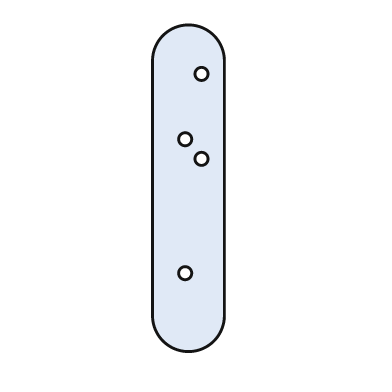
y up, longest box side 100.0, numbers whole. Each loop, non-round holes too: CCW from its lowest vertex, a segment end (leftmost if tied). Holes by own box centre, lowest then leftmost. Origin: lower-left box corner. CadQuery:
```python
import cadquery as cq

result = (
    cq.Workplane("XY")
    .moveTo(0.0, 11.0)
    .threePointArc((11.0, 0.0), (22.0, 11.0))
    .lineTo(22.0, 89.0)
    .threePointArc((11.0, 100.0), (0.0, 89.0))
    .close()
    .moveTo(10.0, 24.0)
    .circle(2.0)
    .moveTo(15.0, 59.0)
    .circle(2.0)
    .moveTo(10.0, 65.0)
    .circle(2.0)
    .moveTo(15.0, 85.0)
    .circle(2.0)
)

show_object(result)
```